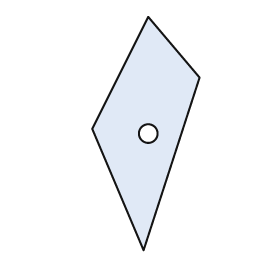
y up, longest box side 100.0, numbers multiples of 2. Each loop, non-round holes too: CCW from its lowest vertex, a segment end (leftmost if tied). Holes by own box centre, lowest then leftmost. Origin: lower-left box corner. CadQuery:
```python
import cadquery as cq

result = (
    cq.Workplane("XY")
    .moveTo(22.0, 0.0)
    .lineTo(46.0, 74.0)
    .lineTo(24.0, 100.0)
    .lineTo(0.0, 52.0)
    .close()
    .moveTo(24.0, 50.0)
    .circle(4.0)
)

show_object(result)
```